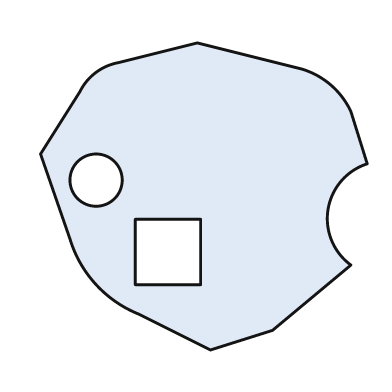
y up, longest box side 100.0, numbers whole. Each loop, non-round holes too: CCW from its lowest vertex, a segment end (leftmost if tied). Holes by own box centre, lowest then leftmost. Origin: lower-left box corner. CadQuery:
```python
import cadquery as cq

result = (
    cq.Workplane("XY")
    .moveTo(52.0, 0.0)
    .lineTo(71.0, 6.0)
    .lineTo(95.0, 26.0)
    .threePointArc((88.0, 43.0), (100.0, 57.0))
    .lineTo(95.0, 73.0)
    .threePointArc((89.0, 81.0), (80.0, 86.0))
    .lineTo(48.0, 94.0)
    .lineTo(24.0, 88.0)
    .threePointArc((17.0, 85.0), (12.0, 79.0))
    .lineTo(0.0, 60.0)
    .lineTo(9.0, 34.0)
    .threePointArc((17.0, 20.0), (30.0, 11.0))
    .close()
    .moveTo(29.0, 20.0)
    .lineTo(49.0, 20.0)
    .lineTo(49.0, 40.0)
    .lineTo(29.0, 40.0)
    .close()
    .moveTo(17.0, 52.0)
    .circle(8.0)
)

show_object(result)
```